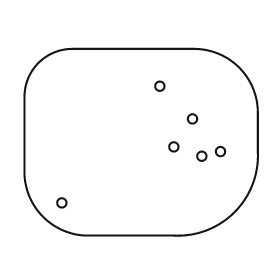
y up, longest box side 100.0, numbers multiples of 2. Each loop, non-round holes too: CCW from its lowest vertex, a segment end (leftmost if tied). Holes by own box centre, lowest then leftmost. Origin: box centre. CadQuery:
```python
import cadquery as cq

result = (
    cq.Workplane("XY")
    .moveTo(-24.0, -40.0)
    .lineTo(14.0, -40.0)
    .threePointArc((40.0, -30.0), (50.0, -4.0))
    .lineTo(50.0, 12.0)
    .threePointArc((42.0, 32.0), (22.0, 40.0))
    .lineTo(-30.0, 40.0)
    .threePointArc((-44.0, 34.0), (-50.0, 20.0))
    .lineTo(-50.0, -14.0)
    .threePointArc((-42.0, -32.0), (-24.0, -40.0))
    .close()
    .moveTo(-34.0, -26.0)
    .circle(2.0)
    .moveTo(26.0, -6.0)
    .circle(2.0)
    .moveTo(34.0, -4.0)
    .circle(2.0)
    .moveTo(14.0, -2.0)
    .circle(2.0)
    .moveTo(22.0, 10.0)
    .circle(2.0)
    .moveTo(8.0, 24.0)
    .circle(2.0)
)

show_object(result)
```